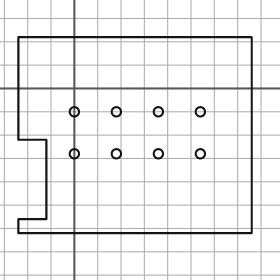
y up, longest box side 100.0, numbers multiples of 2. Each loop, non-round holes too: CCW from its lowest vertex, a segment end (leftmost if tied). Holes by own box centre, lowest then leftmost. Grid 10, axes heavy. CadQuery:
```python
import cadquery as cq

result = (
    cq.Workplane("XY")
    .moveTo(-24.0, -62.0)
    .lineTo(76.0, -62.0)
    .lineTo(76.0, 22.0)
    .lineTo(-24.0, 22.0)
    .lineTo(-24.0, -22.0)
    .lineTo(-12.0, -22.0)
    .lineTo(-12.0, -56.0)
    .lineTo(-24.0, -56.0)
    .close()
    .moveTo(0.0, -28.0)
    .circle(2.0)
    .moveTo(18.0, -28.0)
    .circle(2.0)
    .moveTo(36.0, -28.0)
    .circle(2.0)
    .moveTo(54.0, -28.0)
    .circle(2.0)
    .moveTo(0.0, -10.0)
    .circle(2.0)
    .moveTo(18.0, -10.0)
    .circle(2.0)
    .moveTo(36.0, -10.0)
    .circle(2.0)
    .moveTo(54.0, -10.0)
    .circle(2.0)
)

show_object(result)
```